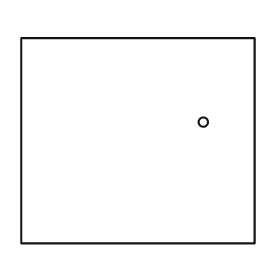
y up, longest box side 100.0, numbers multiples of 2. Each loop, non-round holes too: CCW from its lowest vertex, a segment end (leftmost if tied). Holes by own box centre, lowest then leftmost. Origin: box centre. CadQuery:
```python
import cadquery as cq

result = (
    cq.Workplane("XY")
    .moveTo(-50.0, -44.0)
    .lineTo(50.0, -44.0)
    .lineTo(50.0, 44.0)
    .lineTo(-50.0, 44.0)
    .close()
    .moveTo(28.0, 8.0)
    .circle(2.0)
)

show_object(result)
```